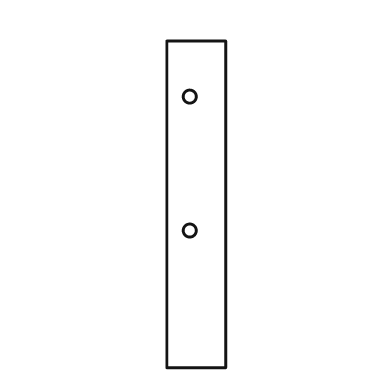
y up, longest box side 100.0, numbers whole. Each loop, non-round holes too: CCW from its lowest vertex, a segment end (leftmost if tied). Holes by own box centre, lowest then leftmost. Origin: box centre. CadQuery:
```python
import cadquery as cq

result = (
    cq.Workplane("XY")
    .moveTo(-9.0, -50.0)
    .lineTo(9.0, -50.0)
    .lineTo(9.0, 50.0)
    .lineTo(-9.0, 50.0)
    .close()
    .moveTo(-2.0, -8.0)
    .circle(2.0)
    .moveTo(-2.0, 33.0)
    .circle(2.0)
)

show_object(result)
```